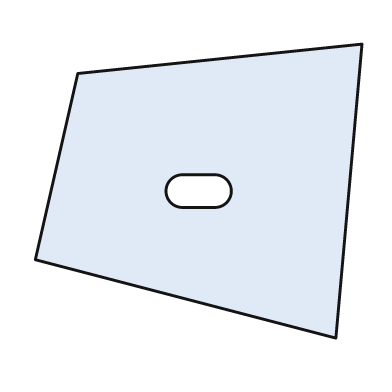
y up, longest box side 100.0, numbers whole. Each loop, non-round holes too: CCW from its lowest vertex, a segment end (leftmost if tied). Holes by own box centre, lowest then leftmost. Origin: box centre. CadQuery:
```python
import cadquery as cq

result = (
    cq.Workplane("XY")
    .moveTo(42.0, -45.0)
    .lineTo(50.0, 45.0)
    .lineTo(-37.0, 36.0)
    .lineTo(-50.0, -21.0)
    .close()
    .moveTo(-5.0, -5.0)
    .lineTo(5.0, -5.0)
    .threePointArc((10.0, 0.0), (5.0, 5.0))
    .lineTo(-5.0, 5.0)
    .threePointArc((-10.0, 0.0), (-5.0, -5.0))
    .close()
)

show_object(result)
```